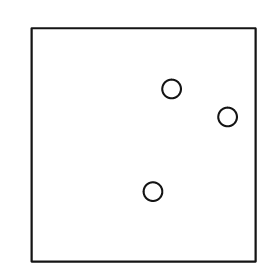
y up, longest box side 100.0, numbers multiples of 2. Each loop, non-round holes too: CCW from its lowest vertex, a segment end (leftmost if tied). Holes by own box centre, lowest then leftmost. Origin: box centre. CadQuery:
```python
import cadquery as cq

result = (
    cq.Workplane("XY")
    .moveTo(-48.0, -50.0)
    .lineTo(48.0, -50.0)
    .lineTo(48.0, 50.0)
    .lineTo(-48.0, 50.0)
    .close()
    .moveTo(4.0, -20.0)
    .circle(4.0)
    .moveTo(36.0, 12.0)
    .circle(4.0)
    .moveTo(12.0, 24.0)
    .circle(4.0)
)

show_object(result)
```